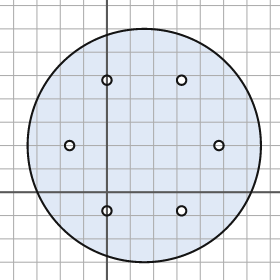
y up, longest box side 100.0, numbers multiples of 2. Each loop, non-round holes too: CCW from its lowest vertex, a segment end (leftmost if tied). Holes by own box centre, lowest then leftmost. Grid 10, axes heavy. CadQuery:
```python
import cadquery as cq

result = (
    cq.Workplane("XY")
    .moveTo(16.0, 20.0)
    .circle(50.0)
    .moveTo(0.0, -8.0)
    .circle(2.0)
    .moveTo(32.0, -8.0)
    .circle(2.0)
    .moveTo(-16.0, 20.0)
    .circle(2.0)
    .moveTo(48.0, 20.0)
    .circle(2.0)
    .moveTo(0.0, 48.0)
    .circle(2.0)
    .moveTo(32.0, 48.0)
    .circle(2.0)
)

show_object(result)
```